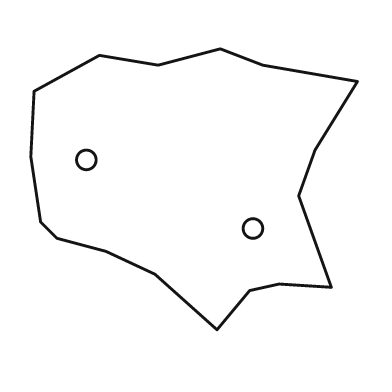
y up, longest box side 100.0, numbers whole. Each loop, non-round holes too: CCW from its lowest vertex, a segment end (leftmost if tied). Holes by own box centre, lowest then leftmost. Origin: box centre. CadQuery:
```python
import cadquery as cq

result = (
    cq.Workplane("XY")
    .moveTo(7.0, -43.0)
    .lineTo(17.0, -31.0)
    .lineTo(26.0, -29.0)
    .lineTo(42.0, -30.0)
    .lineTo(32.0, -2.0)
    .lineTo(37.0, 12.0)
    .lineTo(50.0, 33.0)
    .lineTo(21.0, 38.0)
    .lineTo(8.0, 43.0)
    .lineTo(-11.0, 38.0)
    .lineTo(-29.0, 41.0)
    .lineTo(-49.0, 30.0)
    .lineTo(-50.0, 10.0)
    .lineTo(-47.0, -10.0)
    .lineTo(-42.0, -15.0)
    .lineTo(-27.0, -19.0)
    .lineTo(-12.0, -26.0)
    .close()
    .moveTo(18.0, -12.0)
    .circle(3.0)
    .moveTo(-33.0, 9.0)
    .circle(3.0)
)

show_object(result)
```